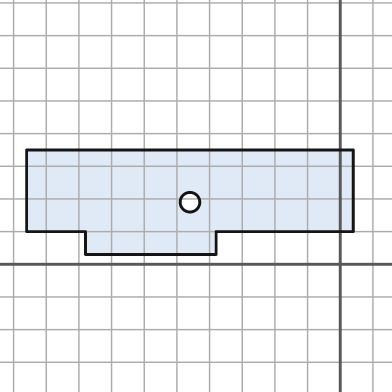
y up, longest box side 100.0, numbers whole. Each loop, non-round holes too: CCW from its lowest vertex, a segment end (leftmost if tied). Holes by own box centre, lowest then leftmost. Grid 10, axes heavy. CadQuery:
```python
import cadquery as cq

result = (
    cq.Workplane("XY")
    .moveTo(-78.0, 3.0)
    .lineTo(-38.0, 3.0)
    .lineTo(-38.0, 10.0)
    .lineTo(4.0, 10.0)
    .lineTo(4.0, 35.0)
    .lineTo(-96.0, 35.0)
    .lineTo(-96.0, 10.0)
    .lineTo(-78.0, 10.0)
    .close()
    .moveTo(-46.0, 19.0)
    .circle(3.0)
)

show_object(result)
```